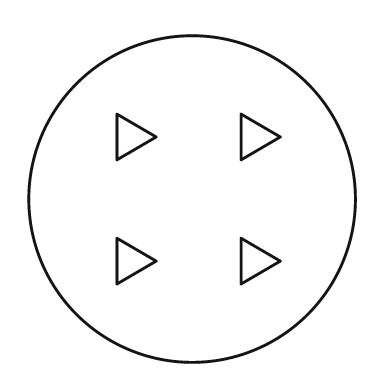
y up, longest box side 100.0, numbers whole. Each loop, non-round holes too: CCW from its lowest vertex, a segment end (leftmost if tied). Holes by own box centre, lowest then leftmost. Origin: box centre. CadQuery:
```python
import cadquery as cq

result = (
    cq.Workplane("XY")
    .moveTo(0.0, 0.0)
    .circle(50.0)
    .moveTo(-23.0, -26.0)
    .lineTo(-11.0, -19.0)
    .lineTo(-23.0, -12.0)
    .close()
    .moveTo(15.0, -26.0)
    .lineTo(27.0, -19.0)
    .lineTo(15.0, -12.0)
    .close()
    .moveTo(-23.0, 12.0)
    .lineTo(-11.0, 19.0)
    .lineTo(-23.0, 26.0)
    .close()
    .moveTo(15.0, 12.0)
    .lineTo(27.0, 19.0)
    .lineTo(15.0, 26.0)
    .close()
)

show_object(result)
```